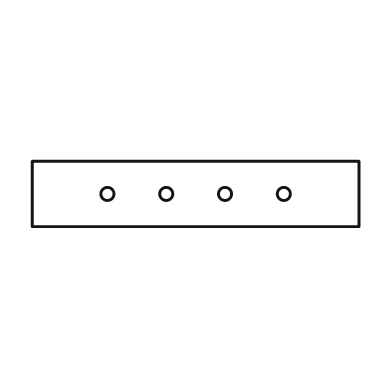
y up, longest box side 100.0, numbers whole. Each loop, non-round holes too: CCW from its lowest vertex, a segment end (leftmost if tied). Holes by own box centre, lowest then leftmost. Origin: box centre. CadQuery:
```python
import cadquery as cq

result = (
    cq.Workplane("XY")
    .moveTo(-50.0, -10.0)
    .lineTo(50.0, -10.0)
    .lineTo(50.0, 10.0)
    .lineTo(-50.0, 10.0)
    .close()
    .moveTo(-27.0, 0.0)
    .circle(2.0)
    .moveTo(-9.0, 0.0)
    .circle(2.0)
    .moveTo(9.0, 0.0)
    .circle(2.0)
    .moveTo(27.0, 0.0)
    .circle(2.0)
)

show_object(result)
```